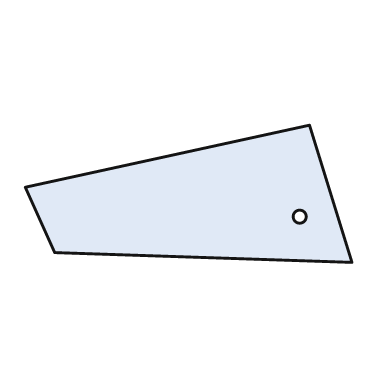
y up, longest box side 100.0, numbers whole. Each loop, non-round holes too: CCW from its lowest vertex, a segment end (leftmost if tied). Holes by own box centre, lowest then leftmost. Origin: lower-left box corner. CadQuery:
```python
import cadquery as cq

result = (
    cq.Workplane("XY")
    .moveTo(100.0, 0.0)
    .lineTo(87.0, 42.0)
    .lineTo(0.0, 23.0)
    .lineTo(9.0, 3.0)
    .close()
    .moveTo(84.0, 14.0)
    .circle(2.0)
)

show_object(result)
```